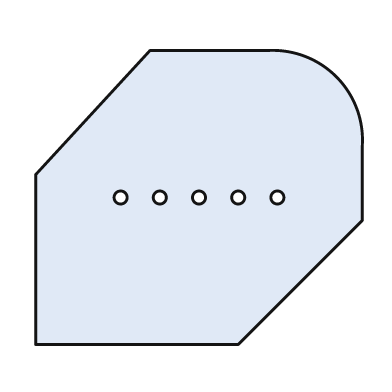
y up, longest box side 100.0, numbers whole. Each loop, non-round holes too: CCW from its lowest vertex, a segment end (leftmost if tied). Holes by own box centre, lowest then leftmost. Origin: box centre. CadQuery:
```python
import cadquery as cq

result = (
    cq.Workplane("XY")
    .moveTo(-50.0, -45.0)
    .lineTo(12.0, -45.0)
    .lineTo(50.0, -7.0)
    .lineTo(50.0, 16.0)
    .threePointArc((42.0, 37.0), (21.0, 45.0))
    .lineTo(-15.0, 45.0)
    .lineTo(-50.0, 7.0)
    .close()
    .moveTo(-24.0, 0.0)
    .circle(2.0)
    .moveTo(-12.0, 0.0)
    .circle(2.0)
    .moveTo(0.0, 0.0)
    .circle(2.0)
    .moveTo(12.0, 0.0)
    .circle(2.0)
    .moveTo(24.0, 0.0)
    .circle(2.0)
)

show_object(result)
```